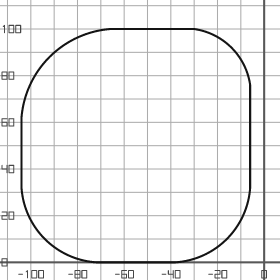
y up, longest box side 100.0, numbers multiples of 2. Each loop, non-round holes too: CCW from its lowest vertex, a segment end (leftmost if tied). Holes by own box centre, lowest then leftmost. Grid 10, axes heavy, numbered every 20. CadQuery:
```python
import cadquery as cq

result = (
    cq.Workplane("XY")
    .moveTo(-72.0, 0.0)
    .lineTo(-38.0, 0.0)
    .threePointArc((-16.0, 10.0), (-6.0, 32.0))
    .lineTo(-6.0, 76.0)
    .threePointArc((-14.0, 92.0), (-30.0, 100.0))
    .lineTo(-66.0, 100.0)
    .threePointArc((-92.0, 88.0), (-104.0, 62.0))
    .lineTo(-104.0, 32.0)
    .threePointArc((-94.0, 10.0), (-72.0, 0.0))
    .close()
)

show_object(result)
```